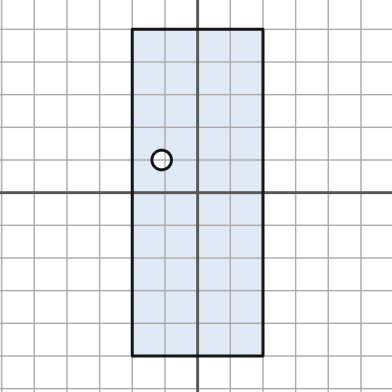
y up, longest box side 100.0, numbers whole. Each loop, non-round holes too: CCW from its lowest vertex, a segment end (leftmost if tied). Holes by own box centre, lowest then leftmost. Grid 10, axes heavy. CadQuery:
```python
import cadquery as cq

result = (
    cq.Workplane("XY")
    .moveTo(-20.0, -50.0)
    .lineTo(20.0, -50.0)
    .lineTo(20.0, 50.0)
    .lineTo(-20.0, 50.0)
    .close()
    .moveTo(-11.0, 10.0)
    .circle(3.0)
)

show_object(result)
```